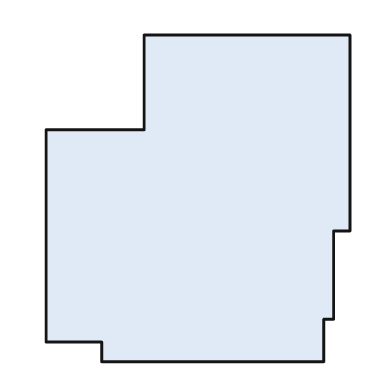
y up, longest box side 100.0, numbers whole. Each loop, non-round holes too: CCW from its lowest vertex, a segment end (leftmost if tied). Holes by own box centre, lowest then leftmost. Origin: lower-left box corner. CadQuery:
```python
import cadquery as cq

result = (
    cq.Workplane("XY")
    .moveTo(17.0, 0.0)
    .lineTo(85.0, 0.0)
    .lineTo(85.0, 13.0)
    .lineTo(88.0, 13.0)
    .lineTo(88.0, 40.0)
    .lineTo(93.0, 40.0)
    .lineTo(93.0, 100.0)
    .lineTo(30.0, 100.0)
    .lineTo(30.0, 71.0)
    .lineTo(0.0, 71.0)
    .lineTo(0.0, 6.0)
    .lineTo(17.0, 6.0)
    .close()
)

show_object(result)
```